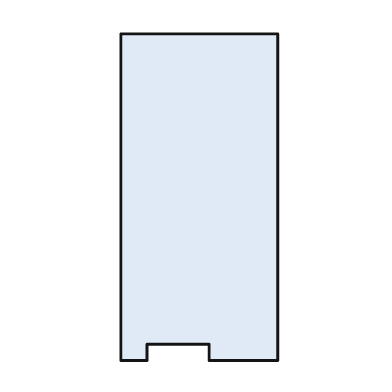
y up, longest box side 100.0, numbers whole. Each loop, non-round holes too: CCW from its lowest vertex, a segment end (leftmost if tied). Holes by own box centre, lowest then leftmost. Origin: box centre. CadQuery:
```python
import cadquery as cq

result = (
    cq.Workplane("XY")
    .moveTo(-24.0, -50.0)
    .lineTo(-16.0, -50.0)
    .lineTo(-16.0, -45.0)
    .lineTo(3.0, -45.0)
    .lineTo(3.0, -50.0)
    .lineTo(24.0, -50.0)
    .lineTo(24.0, 50.0)
    .lineTo(-24.0, 50.0)
    .close()
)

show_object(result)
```